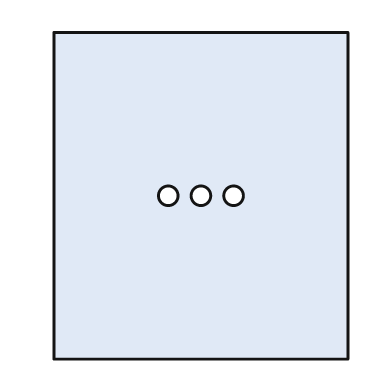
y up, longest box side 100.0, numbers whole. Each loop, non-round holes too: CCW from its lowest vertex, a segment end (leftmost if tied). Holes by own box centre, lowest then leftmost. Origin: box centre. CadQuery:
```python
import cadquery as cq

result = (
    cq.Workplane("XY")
    .moveTo(-45.0, -50.0)
    .lineTo(45.0, -50.0)
    .lineTo(45.0, 50.0)
    .lineTo(-45.0, 50.0)
    .close()
    .moveTo(-10.0, 0.0)
    .circle(3.0)
    .moveTo(0.0, 0.0)
    .circle(3.0)
    .moveTo(10.0, 0.0)
    .circle(3.0)
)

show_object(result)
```